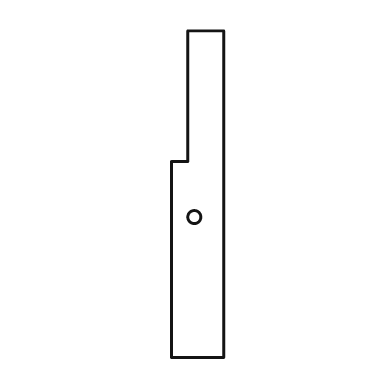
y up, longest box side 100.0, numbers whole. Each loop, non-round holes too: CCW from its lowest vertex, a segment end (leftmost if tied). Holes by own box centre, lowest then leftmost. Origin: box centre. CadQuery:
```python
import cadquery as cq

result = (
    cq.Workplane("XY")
    .moveTo(-8.0, -50.0)
    .lineTo(8.0, -50.0)
    .lineTo(8.0, 50.0)
    .lineTo(-3.0, 50.0)
    .lineTo(-3.0, 10.0)
    .lineTo(-8.0, 10.0)
    .close()
    .moveTo(-1.0, -7.0)
    .circle(2.0)
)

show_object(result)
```